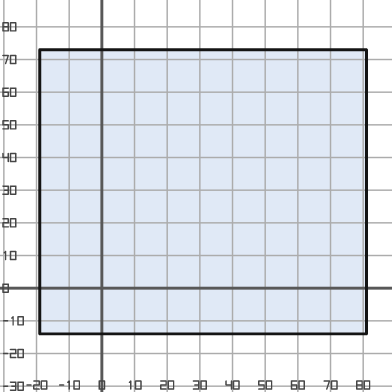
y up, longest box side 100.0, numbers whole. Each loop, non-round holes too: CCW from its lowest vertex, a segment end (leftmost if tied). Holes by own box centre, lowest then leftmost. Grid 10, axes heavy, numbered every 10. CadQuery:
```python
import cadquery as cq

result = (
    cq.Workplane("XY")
    .moveTo(-19.0, -14.0)
    .lineTo(81.0, -14.0)
    .lineTo(81.0, 73.0)
    .lineTo(-19.0, 73.0)
    .close()
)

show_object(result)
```